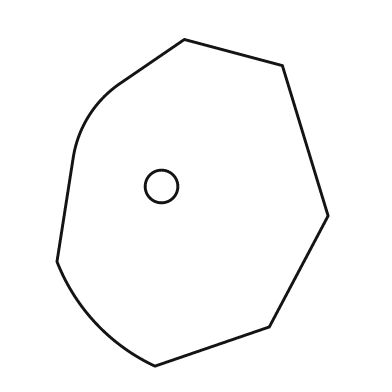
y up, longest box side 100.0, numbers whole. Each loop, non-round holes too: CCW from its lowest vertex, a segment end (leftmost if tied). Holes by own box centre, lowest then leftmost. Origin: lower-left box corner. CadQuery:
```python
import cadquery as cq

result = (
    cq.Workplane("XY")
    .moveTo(30.0, 0.0)
    .lineTo(65.0, 12.0)
    .lineTo(83.0, 46.0)
    .lineTo(69.0, 92.0)
    .lineTo(39.0, 100.0)
    .lineTo(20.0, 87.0)
    .threePointArc((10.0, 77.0), (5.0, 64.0))
    .lineTo(0.0, 32.0)
    .threePointArc((12.0, 13.0), (30.0, 0.0))
    .close()
    .moveTo(32.0, 55.0)
    .circle(5.0)
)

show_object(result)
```